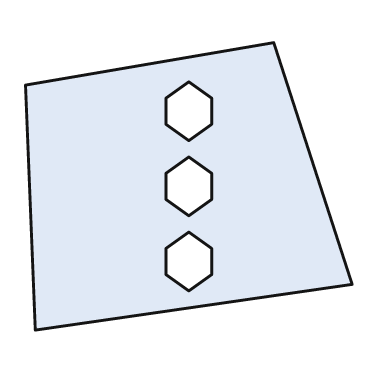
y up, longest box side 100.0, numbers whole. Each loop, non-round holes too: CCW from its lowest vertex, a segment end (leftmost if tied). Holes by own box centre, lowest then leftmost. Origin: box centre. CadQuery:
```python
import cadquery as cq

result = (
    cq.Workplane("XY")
    .moveTo(-47.0, -44.0)
    .lineTo(50.0, -30.0)
    .lineTo(26.0, 44.0)
    .lineTo(-50.0, 31.0)
    .close()
    .moveTo(0.0, -32.0)
    .lineTo(7.0, -27.0)
    .lineTo(7.0, -19.0)
    .lineTo(0.0, -14.0)
    .lineTo(-7.0, -19.0)
    .lineTo(-7.0, -27.0)
    .close()
    .moveTo(0.0, -9.0)
    .lineTo(7.0, -4.0)
    .lineTo(7.0, 4.0)
    .lineTo(0.0, 9.0)
    .lineTo(-7.0, 4.0)
    .lineTo(-7.0, -4.0)
    .close()
    .moveTo(0.0, 14.0)
    .lineTo(7.0, 19.0)
    .lineTo(7.0, 27.0)
    .lineTo(0.0, 32.0)
    .lineTo(-7.0, 27.0)
    .lineTo(-7.0, 19.0)
    .close()
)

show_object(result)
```